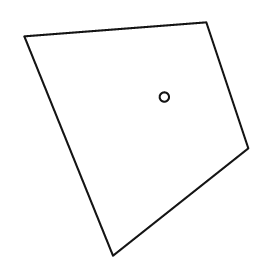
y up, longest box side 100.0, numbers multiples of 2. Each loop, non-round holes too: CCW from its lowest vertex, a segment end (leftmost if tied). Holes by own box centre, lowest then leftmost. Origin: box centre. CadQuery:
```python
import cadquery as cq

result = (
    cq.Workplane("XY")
    .moveTo(-10.0, -50.0)
    .lineTo(48.0, -4.0)
    .lineTo(30.0, 50.0)
    .lineTo(-48.0, 44.0)
    .close()
    .moveTo(12.0, 18.0)
    .circle(2.0)
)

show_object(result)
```